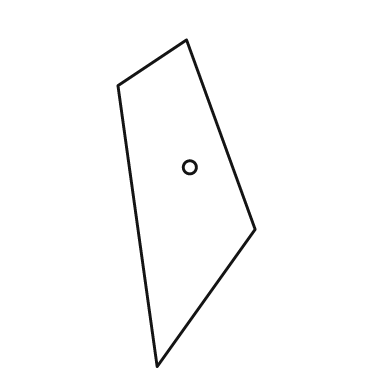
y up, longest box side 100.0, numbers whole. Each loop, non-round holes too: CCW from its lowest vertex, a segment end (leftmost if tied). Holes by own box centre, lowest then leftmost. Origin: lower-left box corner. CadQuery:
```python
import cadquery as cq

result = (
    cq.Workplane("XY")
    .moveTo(12.0, 0.0)
    .lineTo(42.0, 42.0)
    .lineTo(21.0, 100.0)
    .lineTo(0.0, 86.0)
    .close()
    .moveTo(22.0, 61.0)
    .circle(2.0)
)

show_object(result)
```